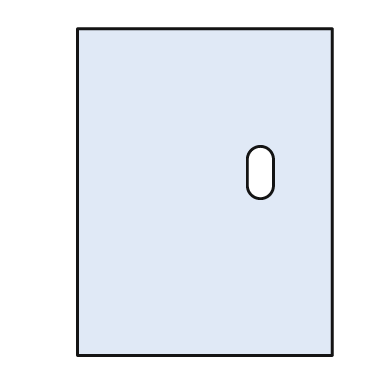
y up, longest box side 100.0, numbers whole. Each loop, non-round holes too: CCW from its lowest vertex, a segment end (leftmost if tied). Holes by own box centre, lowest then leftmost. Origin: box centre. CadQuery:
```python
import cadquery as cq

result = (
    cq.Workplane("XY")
    .moveTo(-39.0, -50.0)
    .lineTo(39.0, -50.0)
    .lineTo(39.0, 50.0)
    .lineTo(-39.0, 50.0)
    .close()
    .moveTo(13.0, 2.0)
    .threePointArc((17.0, -2.0), (21.0, 2.0))
    .lineTo(21.0, 10.0)
    .threePointArc((17.0, 14.0), (13.0, 10.0))
    .close()
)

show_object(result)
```